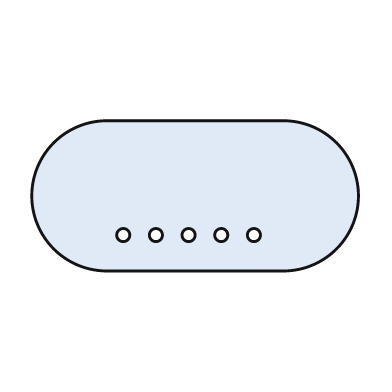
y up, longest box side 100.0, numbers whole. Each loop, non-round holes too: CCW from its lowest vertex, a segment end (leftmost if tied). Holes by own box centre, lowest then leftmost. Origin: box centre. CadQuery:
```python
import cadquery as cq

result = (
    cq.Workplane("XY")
    .moveTo(-27.0, -23.0)
    .lineTo(27.0, -23.0)
    .threePointArc((50.0, 0.0), (27.0, 23.0))
    .lineTo(-27.0, 23.0)
    .threePointArc((-50.0, 0.0), (-27.0, -23.0))
    .close()
    .moveTo(-22.0, -12.0)
    .circle(2.0)
    .moveTo(-12.0, -12.0)
    .circle(2.0)
    .moveTo(-2.0, -12.0)
    .circle(2.0)
    .moveTo(8.0, -12.0)
    .circle(2.0)
    .moveTo(18.0, -12.0)
    .circle(2.0)
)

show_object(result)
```